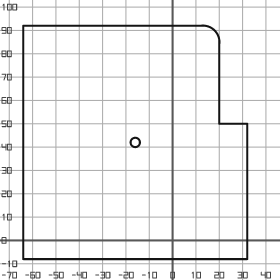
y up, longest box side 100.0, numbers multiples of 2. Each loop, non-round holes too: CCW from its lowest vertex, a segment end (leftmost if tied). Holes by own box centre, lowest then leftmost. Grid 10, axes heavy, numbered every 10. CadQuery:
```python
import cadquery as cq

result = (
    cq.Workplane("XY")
    .moveTo(-64.0, -8.0)
    .lineTo(32.0, -8.0)
    .lineTo(32.0, 50.0)
    .lineTo(20.0, 50.0)
    .lineTo(20.0, 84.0)
    .threePointArc((18.0, 90.0), (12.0, 92.0))
    .lineTo(-64.0, 92.0)
    .close()
    .moveTo(-16.0, 42.0)
    .circle(2.0)
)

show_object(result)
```